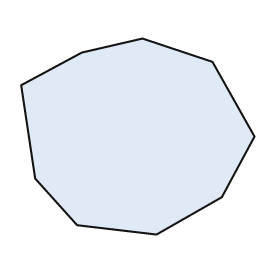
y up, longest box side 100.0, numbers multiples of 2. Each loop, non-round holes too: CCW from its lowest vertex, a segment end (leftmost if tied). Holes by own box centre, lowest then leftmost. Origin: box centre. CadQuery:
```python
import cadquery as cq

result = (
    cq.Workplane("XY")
    .moveTo(8.0, -42.0)
    .lineTo(36.0, -26.0)
    .lineTo(50.0, 0.0)
    .lineTo(32.0, 32.0)
    .lineTo(2.0, 42.0)
    .lineTo(-24.0, 36.0)
    .lineTo(-50.0, 22.0)
    .lineTo(-44.0, -18.0)
    .lineTo(-26.0, -38.0)
    .close()
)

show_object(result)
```